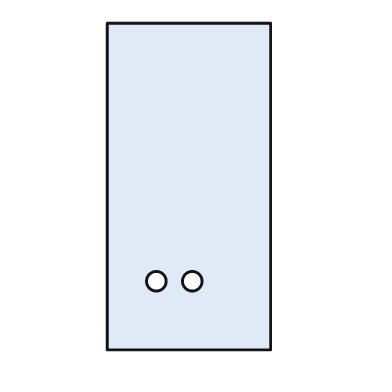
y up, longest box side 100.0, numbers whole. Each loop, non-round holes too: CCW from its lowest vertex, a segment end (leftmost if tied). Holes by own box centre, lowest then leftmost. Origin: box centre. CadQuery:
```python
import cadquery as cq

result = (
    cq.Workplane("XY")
    .moveTo(-25.0, -50.0)
    .lineTo(25.0, -50.0)
    .lineTo(25.0, 50.0)
    .lineTo(-25.0, 50.0)
    .close()
    .moveTo(-10.0, -29.0)
    .circle(3.0)
    .moveTo(1.0, -29.0)
    .circle(3.0)
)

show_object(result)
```